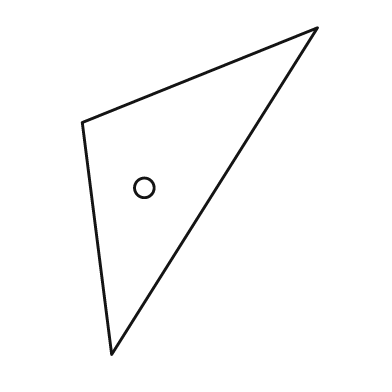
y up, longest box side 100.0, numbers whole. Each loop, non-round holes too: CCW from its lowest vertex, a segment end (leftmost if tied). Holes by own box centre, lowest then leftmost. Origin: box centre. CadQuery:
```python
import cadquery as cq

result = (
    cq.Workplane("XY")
    .moveTo(-27.0, -50.0)
    .lineTo(36.0, 50.0)
    .lineTo(-36.0, 21.0)
    .close()
    .moveTo(-17.0, 1.0)
    .circle(3.0)
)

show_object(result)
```